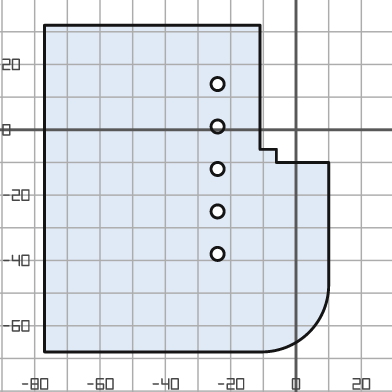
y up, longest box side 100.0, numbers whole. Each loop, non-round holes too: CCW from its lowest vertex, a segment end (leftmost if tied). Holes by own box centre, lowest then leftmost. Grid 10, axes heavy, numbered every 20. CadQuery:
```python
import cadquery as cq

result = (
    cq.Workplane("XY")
    .moveTo(-77.0, -68.0)
    .lineTo(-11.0, -68.0)
    .threePointArc((4.0, -62.0), (10.0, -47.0))
    .lineTo(10.0, -10.0)
    .lineTo(-6.0, -10.0)
    .lineTo(-6.0, -6.0)
    .lineTo(-11.0, -6.0)
    .lineTo(-11.0, 32.0)
    .lineTo(-77.0, 32.0)
    .close()
    .moveTo(-24.0, -38.0)
    .circle(2.0)
    .moveTo(-24.0, -25.0)
    .circle(2.0)
    .moveTo(-24.0, -12.0)
    .circle(2.0)
    .moveTo(-24.0, 1.0)
    .circle(2.0)
    .moveTo(-24.0, 14.0)
    .circle(2.0)
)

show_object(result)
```